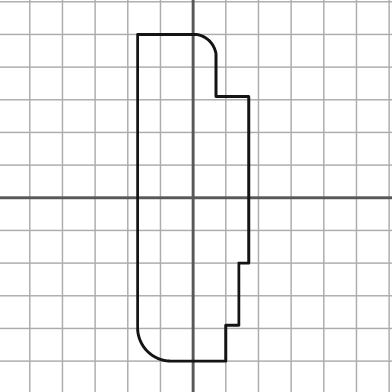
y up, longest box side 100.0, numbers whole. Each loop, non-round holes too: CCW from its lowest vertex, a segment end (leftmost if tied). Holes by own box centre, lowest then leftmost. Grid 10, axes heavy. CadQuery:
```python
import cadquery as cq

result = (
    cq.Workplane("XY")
    .moveTo(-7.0, -50.0)
    .lineTo(10.0, -50.0)
    .lineTo(10.0, -39.0)
    .lineTo(14.0, -39.0)
    .lineTo(14.0, -20.0)
    .lineTo(17.0, -20.0)
    .lineTo(17.0, 31.0)
    .lineTo(7.0, 31.0)
    .lineTo(7.0, 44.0)
    .threePointArc((5.0, 48.0), (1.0, 50.0))
    .lineTo(-17.0, 50.0)
    .lineTo(-17.0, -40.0)
    .threePointArc((-14.0, -47.0), (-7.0, -50.0))
    .close()
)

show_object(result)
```